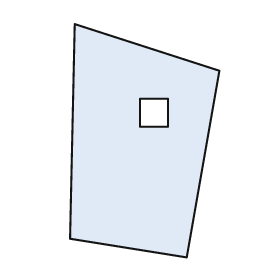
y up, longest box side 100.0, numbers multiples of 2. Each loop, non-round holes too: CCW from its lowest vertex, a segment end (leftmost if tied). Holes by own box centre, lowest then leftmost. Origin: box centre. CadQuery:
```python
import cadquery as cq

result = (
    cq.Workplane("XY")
    .moveTo(18.0, -50.0)
    .lineTo(32.0, 30.0)
    .lineTo(-30.0, 50.0)
    .lineTo(-32.0, -42.0)
    .close()
    .moveTo(-2.0, 6.0)
    .lineTo(10.0, 6.0)
    .lineTo(10.0, 18.0)
    .lineTo(-2.0, 18.0)
    .close()
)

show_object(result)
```